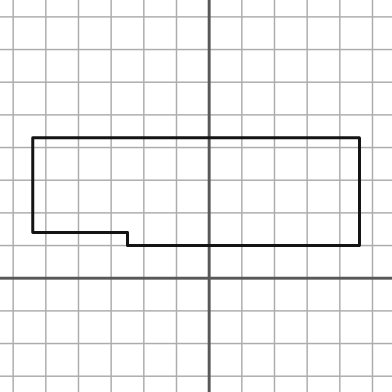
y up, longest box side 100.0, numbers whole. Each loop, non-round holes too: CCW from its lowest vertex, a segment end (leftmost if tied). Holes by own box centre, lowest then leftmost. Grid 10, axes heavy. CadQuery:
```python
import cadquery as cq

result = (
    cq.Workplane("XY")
    .moveTo(-25.0, 10.0)
    .lineTo(46.0, 10.0)
    .lineTo(46.0, 43.0)
    .lineTo(-54.0, 43.0)
    .lineTo(-54.0, 14.0)
    .lineTo(-25.0, 14.0)
    .close()
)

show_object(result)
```